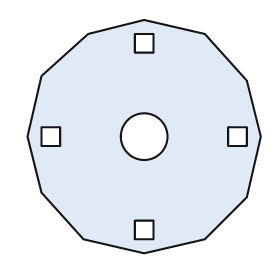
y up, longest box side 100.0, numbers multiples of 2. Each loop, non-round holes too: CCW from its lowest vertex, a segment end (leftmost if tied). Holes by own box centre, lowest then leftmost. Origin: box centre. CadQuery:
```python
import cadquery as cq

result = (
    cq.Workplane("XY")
    .moveTo(0.0, -50.0)
    .lineTo(26.0, -44.0)
    .lineTo(44.0, -26.0)
    .lineTo(50.0, 0.0)
    .lineTo(44.0, 24.0)
    .lineTo(26.0, 44.0)
    .lineTo(0.0, 50.0)
    .lineTo(-24.0, 44.0)
    .lineTo(-44.0, 26.0)
    .lineTo(-50.0, 0.0)
    .lineTo(-44.0, -24.0)
    .lineTo(-26.0, -44.0)
    .close()
    .moveTo(-4.0, -44.0)
    .lineTo(4.0, -44.0)
    .lineTo(4.0, -36.0)
    .lineTo(-4.0, -36.0)
    .close()
    .moveTo(-44.0, -4.0)
    .lineTo(-36.0, -4.0)
    .lineTo(-36.0, 4.0)
    .lineTo(-44.0, 4.0)
    .close()
    .moveTo(0.0, 0.0)
    .circle(10.0)
    .moveTo(36.0, -4.0)
    .lineTo(44.0, -4.0)
    .lineTo(44.0, 4.0)
    .lineTo(36.0, 4.0)
    .close()
    .moveTo(-4.0, 36.0)
    .lineTo(4.0, 36.0)
    .lineTo(4.0, 44.0)
    .lineTo(-4.0, 44.0)
    .close()
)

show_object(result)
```